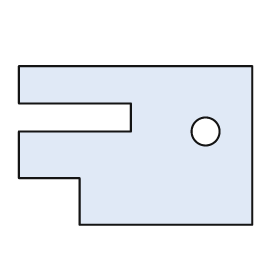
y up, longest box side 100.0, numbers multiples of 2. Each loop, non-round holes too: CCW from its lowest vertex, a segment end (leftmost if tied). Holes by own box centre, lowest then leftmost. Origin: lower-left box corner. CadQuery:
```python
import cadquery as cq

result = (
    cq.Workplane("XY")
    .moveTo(26.0, 0.0)
    .lineTo(100.0, 0.0)
    .lineTo(100.0, 68.0)
    .lineTo(0.0, 68.0)
    .lineTo(0.0, 52.0)
    .lineTo(48.0, 52.0)
    .lineTo(48.0, 40.0)
    .lineTo(0.0, 40.0)
    .lineTo(0.0, 20.0)
    .lineTo(26.0, 20.0)
    .close()
    .moveTo(80.0, 40.0)
    .circle(6.0)
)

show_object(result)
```